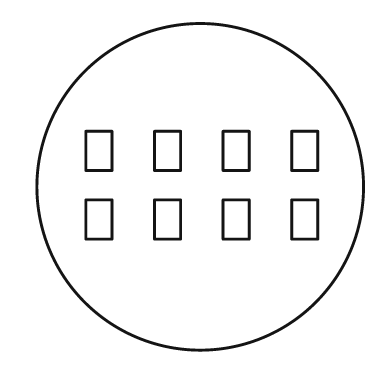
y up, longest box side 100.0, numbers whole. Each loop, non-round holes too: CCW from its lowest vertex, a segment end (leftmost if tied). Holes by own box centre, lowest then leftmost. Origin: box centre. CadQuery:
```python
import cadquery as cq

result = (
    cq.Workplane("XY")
    .moveTo(0.0, 0.0)
    .circle(50.0)
    .moveTo(-35.0, -16.0)
    .lineTo(-27.0, -16.0)
    .lineTo(-27.0, -4.0)
    .lineTo(-35.0, -4.0)
    .close()
    .moveTo(-14.0, -16.0)
    .lineTo(-6.0, -16.0)
    .lineTo(-6.0, -4.0)
    .lineTo(-14.0, -4.0)
    .close()
    .moveTo(7.0, -16.0)
    .lineTo(15.0, -16.0)
    .lineTo(15.0, -4.0)
    .lineTo(7.0, -4.0)
    .close()
    .moveTo(28.0, -16.0)
    .lineTo(36.0, -16.0)
    .lineTo(36.0, -4.0)
    .lineTo(28.0, -4.0)
    .close()
    .moveTo(-35.0, 5.0)
    .lineTo(-27.0, 5.0)
    .lineTo(-27.0, 17.0)
    .lineTo(-35.0, 17.0)
    .close()
    .moveTo(-14.0, 5.0)
    .lineTo(-6.0, 5.0)
    .lineTo(-6.0, 17.0)
    .lineTo(-14.0, 17.0)
    .close()
    .moveTo(7.0, 5.0)
    .lineTo(15.0, 5.0)
    .lineTo(15.0, 17.0)
    .lineTo(7.0, 17.0)
    .close()
    .moveTo(28.0, 5.0)
    .lineTo(36.0, 5.0)
    .lineTo(36.0, 17.0)
    .lineTo(28.0, 17.0)
    .close()
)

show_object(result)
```